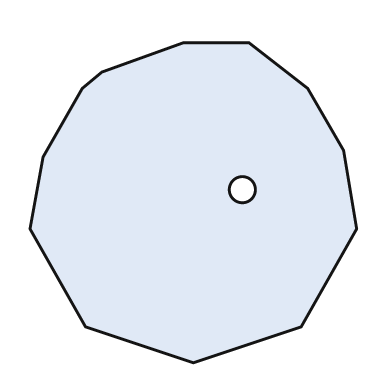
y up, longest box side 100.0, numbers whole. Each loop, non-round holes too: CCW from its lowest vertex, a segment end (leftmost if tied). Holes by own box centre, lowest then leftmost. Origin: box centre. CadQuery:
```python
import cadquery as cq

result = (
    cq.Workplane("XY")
    .moveTo(0.0, -49.0)
    .lineTo(33.0, -38.0)
    .lineTo(50.0, -8.0)
    .lineTo(46.0, 16.0)
    .lineTo(35.0, 35.0)
    .lineTo(17.0, 49.0)
    .lineTo(-3.0, 49.0)
    .lineTo(-28.0, 40.0)
    .lineTo(-34.0, 35.0)
    .lineTo(-46.0, 14.0)
    .lineTo(-50.0, -8.0)
    .lineTo(-33.0, -38.0)
    .close()
    .moveTo(15.0, 4.0)
    .circle(4.0)
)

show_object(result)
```